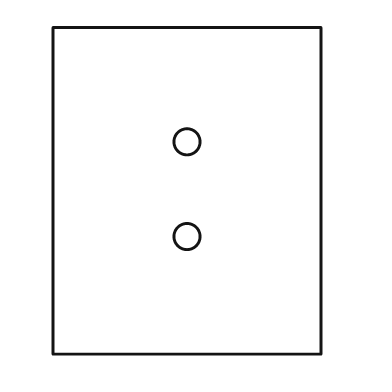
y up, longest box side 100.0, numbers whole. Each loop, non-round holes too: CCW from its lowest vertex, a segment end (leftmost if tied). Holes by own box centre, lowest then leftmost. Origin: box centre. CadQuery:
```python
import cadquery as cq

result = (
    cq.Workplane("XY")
    .moveTo(-41.0, -50.0)
    .lineTo(41.0, -50.0)
    .lineTo(41.0, 50.0)
    .lineTo(-41.0, 50.0)
    .close()
    .moveTo(0.0, -14.0)
    .circle(4.0)
    .moveTo(0.0, 15.0)
    .circle(4.0)
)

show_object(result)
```